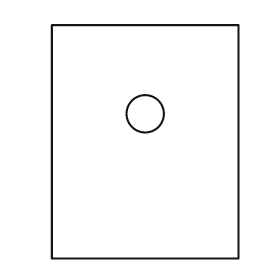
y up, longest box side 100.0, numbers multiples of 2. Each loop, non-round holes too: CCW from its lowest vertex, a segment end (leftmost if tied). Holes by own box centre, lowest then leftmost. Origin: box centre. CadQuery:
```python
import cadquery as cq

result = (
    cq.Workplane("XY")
    .moveTo(-40.0, -50.0)
    .lineTo(40.0, -50.0)
    .lineTo(40.0, 50.0)
    .lineTo(-40.0, 50.0)
    .close()
    .moveTo(0.0, 12.0)
    .circle(8.0)
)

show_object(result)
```